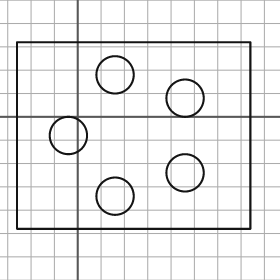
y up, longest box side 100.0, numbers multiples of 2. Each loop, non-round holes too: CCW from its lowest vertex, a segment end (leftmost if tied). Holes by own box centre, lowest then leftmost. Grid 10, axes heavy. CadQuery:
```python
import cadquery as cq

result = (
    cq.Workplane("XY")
    .moveTo(-26.0, -48.0)
    .lineTo(74.0, -48.0)
    .lineTo(74.0, 32.0)
    .lineTo(-26.0, 32.0)
    .close()
    .moveTo(16.0, -34.0)
    .circle(8.0)
    .moveTo(46.0, -24.0)
    .circle(8.0)
    .moveTo(-4.0, -8.0)
    .circle(8.0)
    .moveTo(46.0, 8.0)
    .circle(8.0)
    .moveTo(16.0, 18.0)
    .circle(8.0)
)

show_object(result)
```